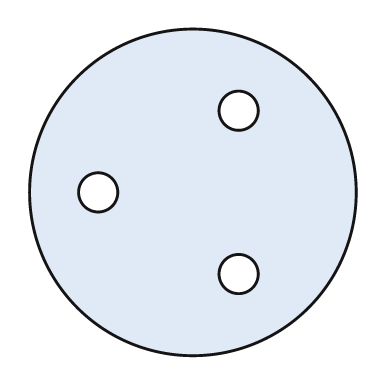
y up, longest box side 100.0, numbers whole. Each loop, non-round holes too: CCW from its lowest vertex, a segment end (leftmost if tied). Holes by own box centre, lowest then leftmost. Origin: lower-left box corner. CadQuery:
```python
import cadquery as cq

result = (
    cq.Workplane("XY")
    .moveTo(50.0, 50.0)
    .circle(50.0)
    .moveTo(64.0, 25.0)
    .circle(6.0)
    .moveTo(21.0, 50.0)
    .circle(6.0)
    .moveTo(64.0, 75.0)
    .circle(6.0)
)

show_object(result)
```